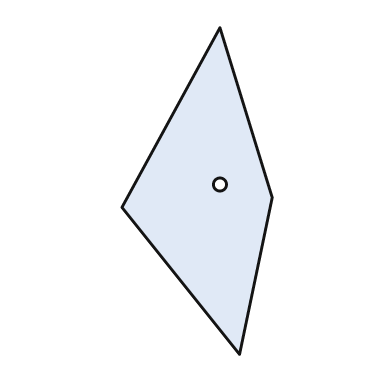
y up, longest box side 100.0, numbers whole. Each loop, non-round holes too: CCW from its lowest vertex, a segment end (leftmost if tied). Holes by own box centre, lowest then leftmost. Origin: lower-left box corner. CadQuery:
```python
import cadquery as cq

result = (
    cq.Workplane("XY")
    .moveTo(36.0, 0.0)
    .lineTo(46.0, 48.0)
    .lineTo(30.0, 100.0)
    .lineTo(0.0, 45.0)
    .close()
    .moveTo(30.0, 52.0)
    .circle(2.0)
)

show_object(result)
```